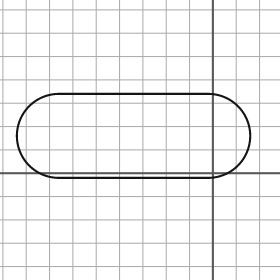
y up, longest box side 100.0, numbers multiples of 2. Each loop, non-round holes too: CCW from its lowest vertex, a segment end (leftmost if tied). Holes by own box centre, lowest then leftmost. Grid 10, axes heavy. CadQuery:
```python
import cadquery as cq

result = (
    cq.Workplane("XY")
    .moveTo(-66.0, -2.0)
    .lineTo(-2.0, -2.0)
    .threePointArc((16.0, 16.0), (-2.0, 34.0))
    .lineTo(-66.0, 34.0)
    .threePointArc((-84.0, 16.0), (-66.0, -2.0))
    .close()
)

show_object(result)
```